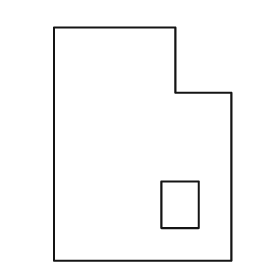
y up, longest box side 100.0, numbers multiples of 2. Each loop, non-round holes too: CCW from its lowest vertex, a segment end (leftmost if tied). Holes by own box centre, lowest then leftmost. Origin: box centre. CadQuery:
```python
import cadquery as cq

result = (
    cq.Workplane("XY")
    .moveTo(-38.0, -50.0)
    .lineTo(38.0, -50.0)
    .lineTo(38.0, 22.0)
    .lineTo(14.0, 22.0)
    .lineTo(14.0, 50.0)
    .lineTo(-38.0, 50.0)
    .close()
    .moveTo(8.0, -36.0)
    .lineTo(24.0, -36.0)
    .lineTo(24.0, -16.0)
    .lineTo(8.0, -16.0)
    .close()
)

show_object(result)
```